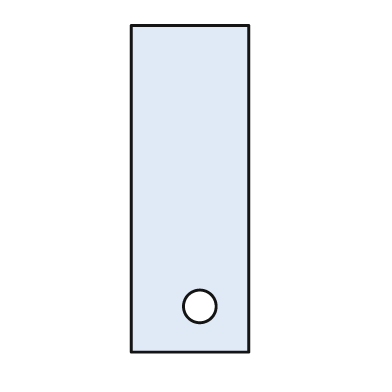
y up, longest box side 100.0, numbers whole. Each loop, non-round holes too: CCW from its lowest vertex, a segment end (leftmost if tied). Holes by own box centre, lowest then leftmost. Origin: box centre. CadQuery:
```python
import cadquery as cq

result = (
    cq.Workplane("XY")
    .moveTo(-18.0, -50.0)
    .lineTo(18.0, -50.0)
    .lineTo(18.0, 50.0)
    .lineTo(-18.0, 50.0)
    .close()
    .moveTo(3.0, -36.0)
    .circle(5.0)
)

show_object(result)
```